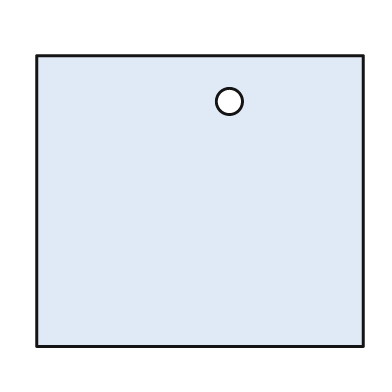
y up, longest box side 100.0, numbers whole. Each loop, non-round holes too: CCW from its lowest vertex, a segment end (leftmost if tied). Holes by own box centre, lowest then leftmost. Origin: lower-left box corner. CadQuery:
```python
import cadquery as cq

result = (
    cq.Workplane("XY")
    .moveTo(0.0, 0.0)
    .lineTo(100.0, 0.0)
    .lineTo(100.0, 89.0)
    .lineTo(0.0, 89.0)
    .close()
    .moveTo(59.0, 75.0)
    .circle(4.0)
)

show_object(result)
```